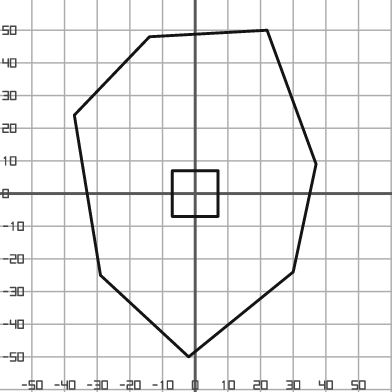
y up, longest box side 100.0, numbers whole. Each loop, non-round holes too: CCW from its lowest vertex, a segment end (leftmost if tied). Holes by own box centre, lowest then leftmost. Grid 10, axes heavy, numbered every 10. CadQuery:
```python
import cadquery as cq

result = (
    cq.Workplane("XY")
    .moveTo(-2.0, -50.0)
    .lineTo(30.0, -24.0)
    .lineTo(37.0, 9.0)
    .lineTo(22.0, 50.0)
    .lineTo(-14.0, 48.0)
    .lineTo(-37.0, 24.0)
    .lineTo(-29.0, -25.0)
    .close()
    .moveTo(-7.0, -7.0)
    .lineTo(7.0, -7.0)
    .lineTo(7.0, 7.0)
    .lineTo(-7.0, 7.0)
    .close()
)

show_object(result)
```